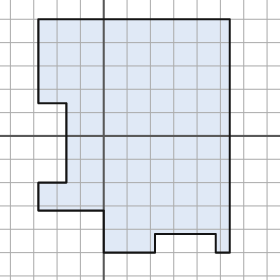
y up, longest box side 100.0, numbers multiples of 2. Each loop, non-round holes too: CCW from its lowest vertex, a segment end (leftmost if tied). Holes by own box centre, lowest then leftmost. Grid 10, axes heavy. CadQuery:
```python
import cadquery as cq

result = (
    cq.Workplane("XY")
    .moveTo(0.0, -50.0)
    .lineTo(22.0, -50.0)
    .lineTo(22.0, -42.0)
    .lineTo(48.0, -42.0)
    .lineTo(48.0, -50.0)
    .lineTo(54.0, -50.0)
    .lineTo(54.0, 50.0)
    .lineTo(-28.0, 50.0)
    .lineTo(-28.0, 14.0)
    .lineTo(-16.0, 14.0)
    .lineTo(-16.0, -20.0)
    .lineTo(-28.0, -20.0)
    .lineTo(-28.0, -32.0)
    .lineTo(0.0, -32.0)
    .close()
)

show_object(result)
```